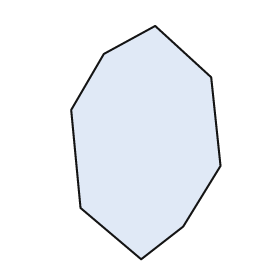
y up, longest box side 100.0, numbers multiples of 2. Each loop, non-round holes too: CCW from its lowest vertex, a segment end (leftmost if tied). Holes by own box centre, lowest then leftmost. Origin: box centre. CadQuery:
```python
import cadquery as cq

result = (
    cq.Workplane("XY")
    .moveTo(-2.0, -50.0)
    .lineTo(16.0, -36.0)
    .lineTo(32.0, -10.0)
    .lineTo(28.0, 28.0)
    .lineTo(4.0, 50.0)
    .lineTo(-18.0, 38.0)
    .lineTo(-32.0, 14.0)
    .lineTo(-28.0, -28.0)
    .close()
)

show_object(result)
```